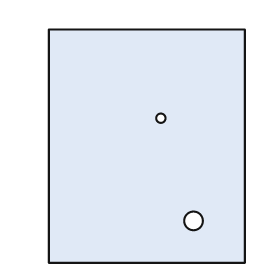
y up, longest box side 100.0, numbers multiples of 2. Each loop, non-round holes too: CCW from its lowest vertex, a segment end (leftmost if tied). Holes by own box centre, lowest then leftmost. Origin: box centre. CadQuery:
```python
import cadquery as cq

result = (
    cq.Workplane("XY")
    .moveTo(-42.0, -50.0)
    .lineTo(42.0, -50.0)
    .lineTo(42.0, 50.0)
    .lineTo(-42.0, 50.0)
    .close()
    .moveTo(20.0, -32.0)
    .circle(4.0)
    .moveTo(6.0, 12.0)
    .circle(2.0)
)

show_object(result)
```